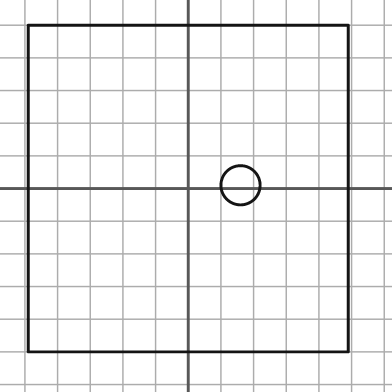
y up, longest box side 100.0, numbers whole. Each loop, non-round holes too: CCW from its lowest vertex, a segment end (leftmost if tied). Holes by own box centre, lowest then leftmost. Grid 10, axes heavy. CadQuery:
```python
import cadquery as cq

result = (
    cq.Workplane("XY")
    .moveTo(-49.0, -50.0)
    .lineTo(49.0, -50.0)
    .lineTo(49.0, 50.0)
    .lineTo(-49.0, 50.0)
    .close()
    .moveTo(16.0, 1.0)
    .circle(6.0)
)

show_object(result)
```